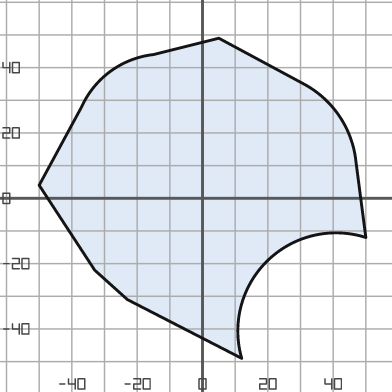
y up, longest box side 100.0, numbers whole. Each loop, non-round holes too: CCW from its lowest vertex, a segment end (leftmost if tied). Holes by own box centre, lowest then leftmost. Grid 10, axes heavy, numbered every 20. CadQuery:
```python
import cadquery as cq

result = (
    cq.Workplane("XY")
    .moveTo(12.0, -49.0)
    .threePointArc((20.0, -19.0), (50.0, -12.0))
    .lineTo(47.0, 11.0)
    .threePointArc((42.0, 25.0), (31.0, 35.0))
    .lineTo(5.0, 49.0)
    .lineTo(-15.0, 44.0)
    .threePointArc((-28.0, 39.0), (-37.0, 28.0))
    .lineTo(-50.0, 4.0)
    .lineTo(-33.0, -22.0)
    .lineTo(-23.0, -31.0)
    .close()
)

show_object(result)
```